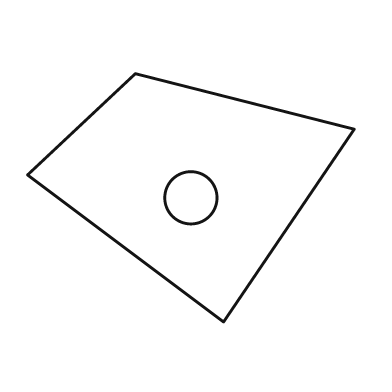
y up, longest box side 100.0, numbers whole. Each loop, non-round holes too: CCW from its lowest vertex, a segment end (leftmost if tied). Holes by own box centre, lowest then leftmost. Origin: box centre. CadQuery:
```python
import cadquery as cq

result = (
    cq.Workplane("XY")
    .moveTo(10.0, -38.0)
    .lineTo(50.0, 21.0)
    .lineTo(-17.0, 38.0)
    .lineTo(-50.0, 7.0)
    .close()
    .moveTo(0.0, 0.0)
    .circle(8.0)
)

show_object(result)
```